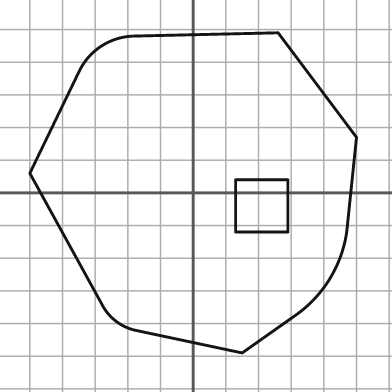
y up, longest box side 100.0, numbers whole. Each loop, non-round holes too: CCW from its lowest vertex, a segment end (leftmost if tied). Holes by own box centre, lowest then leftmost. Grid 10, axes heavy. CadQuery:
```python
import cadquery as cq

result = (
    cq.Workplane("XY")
    .moveTo(15.0, -49.0)
    .lineTo(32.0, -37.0)
    .threePointArc((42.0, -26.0), (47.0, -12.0))
    .lineTo(50.0, 17.0)
    .lineTo(26.0, 49.0)
    .lineTo(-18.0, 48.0)
    .threePointArc((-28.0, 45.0), (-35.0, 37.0))
    .lineTo(-50.0, 6.0)
    .lineTo(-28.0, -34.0)
    .threePointArc((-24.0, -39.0), (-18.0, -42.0))
    .close()
    .moveTo(13.0, -12.0)
    .lineTo(29.0, -12.0)
    .lineTo(29.0, 4.0)
    .lineTo(13.0, 4.0)
    .close()
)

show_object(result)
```